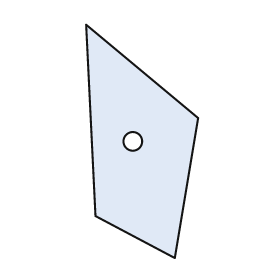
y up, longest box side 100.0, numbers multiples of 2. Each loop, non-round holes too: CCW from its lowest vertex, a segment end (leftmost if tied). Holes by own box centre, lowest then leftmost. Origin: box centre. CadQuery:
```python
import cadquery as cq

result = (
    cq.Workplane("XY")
    .moveTo(14.0, -50.0)
    .lineTo(24.0, 10.0)
    .lineTo(-24.0, 50.0)
    .lineTo(-20.0, -32.0)
    .close()
    .moveTo(-4.0, 0.0)
    .circle(4.0)
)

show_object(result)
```